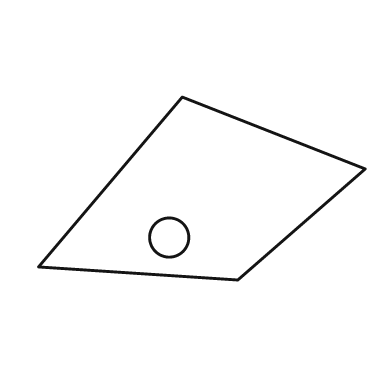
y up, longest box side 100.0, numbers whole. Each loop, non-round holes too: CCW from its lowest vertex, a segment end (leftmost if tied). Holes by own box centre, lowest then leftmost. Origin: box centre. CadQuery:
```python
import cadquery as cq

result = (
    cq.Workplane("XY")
    .moveTo(11.0, -28.0)
    .lineTo(50.0, 6.0)
    .lineTo(-6.0, 28.0)
    .lineTo(-50.0, -24.0)
    .close()
    .moveTo(-10.0, -15.0)
    .circle(6.0)
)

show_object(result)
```